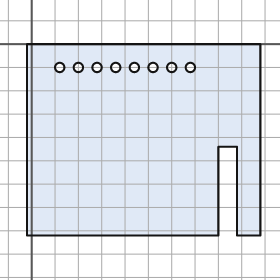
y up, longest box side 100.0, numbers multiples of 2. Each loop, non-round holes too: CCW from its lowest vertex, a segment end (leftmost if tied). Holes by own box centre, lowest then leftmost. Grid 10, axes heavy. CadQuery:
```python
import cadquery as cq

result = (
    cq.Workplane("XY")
    .moveTo(-2.0, -82.0)
    .lineTo(80.0, -82.0)
    .lineTo(80.0, -44.0)
    .lineTo(88.0, -44.0)
    .lineTo(88.0, -82.0)
    .lineTo(98.0, -82.0)
    .lineTo(98.0, 0.0)
    .lineTo(-2.0, 0.0)
    .close()
    .moveTo(12.0, -10.0)
    .circle(2.0)
    .moveTo(20.0, -10.0)
    .circle(2.0)
    .moveTo(28.0, -10.0)
    .circle(2.0)
    .moveTo(36.0, -10.0)
    .circle(2.0)
    .moveTo(44.0, -10.0)
    .circle(2.0)
    .moveTo(52.0, -10.0)
    .circle(2.0)
    .moveTo(60.0, -10.0)
    .circle(2.0)
    .moveTo(68.0, -10.0)
    .circle(2.0)
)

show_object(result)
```